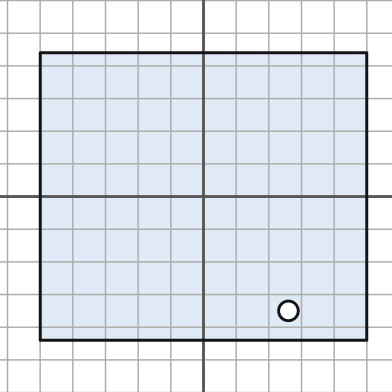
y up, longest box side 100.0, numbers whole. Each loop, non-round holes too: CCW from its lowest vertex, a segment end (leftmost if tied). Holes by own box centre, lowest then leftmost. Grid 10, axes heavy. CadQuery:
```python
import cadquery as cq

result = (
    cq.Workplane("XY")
    .moveTo(-50.0, -44.0)
    .lineTo(50.0, -44.0)
    .lineTo(50.0, 44.0)
    .lineTo(-50.0, 44.0)
    .close()
    .moveTo(26.0, -35.0)
    .circle(3.0)
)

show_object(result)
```